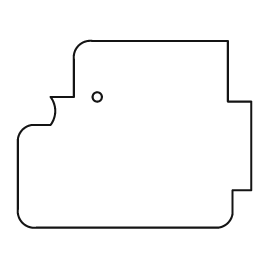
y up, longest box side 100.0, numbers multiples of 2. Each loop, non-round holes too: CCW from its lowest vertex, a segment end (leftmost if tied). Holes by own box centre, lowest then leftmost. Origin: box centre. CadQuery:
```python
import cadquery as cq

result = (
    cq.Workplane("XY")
    .moveTo(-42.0, -40.0)
    .lineTo(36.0, -40.0)
    .threePointArc((40.0, -38.0), (42.0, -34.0))
    .lineTo(42.0, -24.0)
    .lineTo(50.0, -24.0)
    .lineTo(50.0, 14.0)
    .lineTo(40.0, 14.0)
    .lineTo(40.0, 40.0)
    .lineTo(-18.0, 40.0)
    .threePointArc((-24.0, 38.0), (-26.0, 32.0))
    .lineTo(-26.0, 16.0)
    .lineTo(-36.0, 16.0)
    .threePointArc((-34.0, 10.0), (-36.0, 4.0))
    .lineTo(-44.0, 4.0)
    .threePointArc((-48.0, 2.0), (-50.0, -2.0))
    .lineTo(-50.0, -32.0)
    .threePointArc((-48.0, -38.0), (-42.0, -40.0))
    .close()
    .moveTo(-16.0, 16.0)
    .circle(2.0)
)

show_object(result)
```